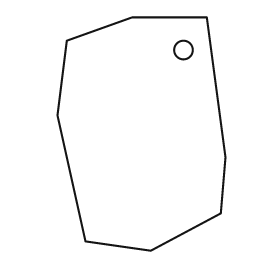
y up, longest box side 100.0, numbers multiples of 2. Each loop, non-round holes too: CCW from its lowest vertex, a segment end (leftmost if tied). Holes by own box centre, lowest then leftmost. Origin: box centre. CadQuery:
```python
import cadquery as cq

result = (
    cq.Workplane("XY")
    .moveTo(4.0, -50.0)
    .lineTo(34.0, -34.0)
    .lineTo(36.0, -10.0)
    .lineTo(28.0, 50.0)
    .lineTo(-4.0, 50.0)
    .lineTo(-32.0, 40.0)
    .lineTo(-36.0, 8.0)
    .lineTo(-24.0, -46.0)
    .close()
    .moveTo(18.0, 36.0)
    .circle(4.0)
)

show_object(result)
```